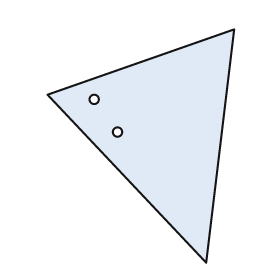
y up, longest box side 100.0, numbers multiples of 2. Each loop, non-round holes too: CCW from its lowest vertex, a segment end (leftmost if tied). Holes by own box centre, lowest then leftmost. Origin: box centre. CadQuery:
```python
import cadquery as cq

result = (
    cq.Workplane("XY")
    .moveTo(28.0, -50.0)
    .lineTo(40.0, 50.0)
    .lineTo(-40.0, 22.0)
    .close()
    .moveTo(-10.0, 6.0)
    .circle(2.0)
    .moveTo(-20.0, 20.0)
    .circle(2.0)
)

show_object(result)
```